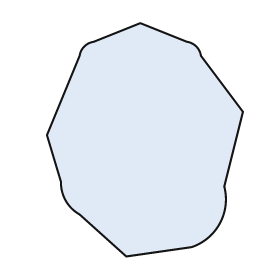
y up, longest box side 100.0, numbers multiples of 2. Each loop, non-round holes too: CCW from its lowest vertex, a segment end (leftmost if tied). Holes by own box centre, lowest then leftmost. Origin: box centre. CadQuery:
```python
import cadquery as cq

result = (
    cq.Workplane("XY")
    .moveTo(-8.0, -50.0)
    .lineTo(20.0, -46.0)
    .threePointArc((32.0, -36.0), (34.0, -20.0))
    .lineTo(42.0, 12.0)
    .lineTo(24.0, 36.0)
    .threePointArc((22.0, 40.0), (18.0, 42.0))
    .lineTo(-2.0, 50.0)
    .lineTo(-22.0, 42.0)
    .threePointArc((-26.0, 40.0), (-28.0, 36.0))
    .lineTo(-42.0, 2.0)
    .lineTo(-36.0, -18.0)
    .threePointArc((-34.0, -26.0), (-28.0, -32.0))
    .close()
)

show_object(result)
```